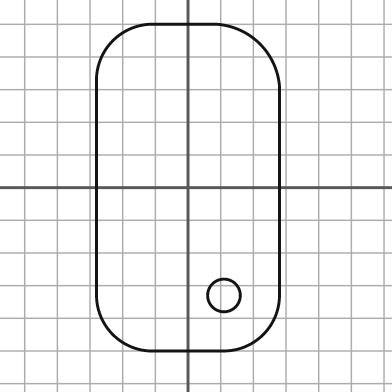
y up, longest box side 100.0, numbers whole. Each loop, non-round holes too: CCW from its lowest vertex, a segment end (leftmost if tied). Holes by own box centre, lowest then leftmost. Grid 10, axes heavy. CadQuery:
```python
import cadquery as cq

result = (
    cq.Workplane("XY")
    .moveTo(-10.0, -50.0)
    .lineTo(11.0, -50.0)
    .threePointArc((23.0, -45.0), (28.0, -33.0))
    .lineTo(28.0, 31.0)
    .threePointArc((22.0, 44.0), (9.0, 50.0))
    .lineTo(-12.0, 50.0)
    .threePointArc((-23.0, 45.0), (-28.0, 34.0))
    .lineTo(-28.0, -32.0)
    .threePointArc((-23.0, -45.0), (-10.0, -50.0))
    .close()
    .moveTo(11.0, -33.0)
    .circle(5.0)
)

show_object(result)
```